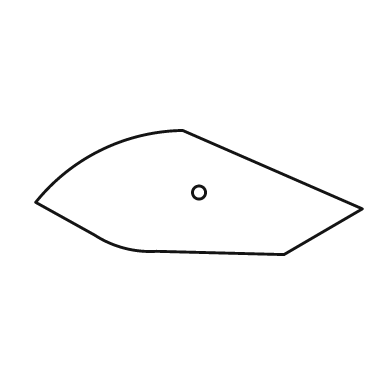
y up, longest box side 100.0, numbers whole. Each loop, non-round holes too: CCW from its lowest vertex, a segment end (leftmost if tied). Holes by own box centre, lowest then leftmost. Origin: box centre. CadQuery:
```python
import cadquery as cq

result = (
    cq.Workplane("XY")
    .moveTo(26.0, -19.0)
    .lineTo(50.0, -5.0)
    .lineTo(-5.0, 19.0)
    .threePointArc((-30.0, 13.0), (-50.0, -3.0))
    .lineTo(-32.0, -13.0)
    .threePointArc((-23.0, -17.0), (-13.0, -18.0))
    .close()
    .moveTo(0.0, 0.0)
    .circle(2.0)
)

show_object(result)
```